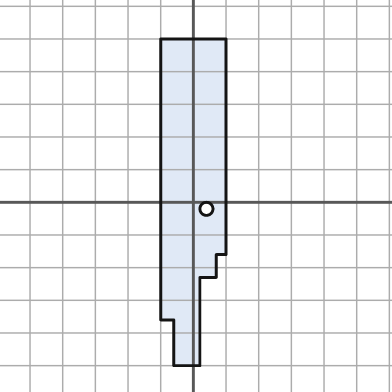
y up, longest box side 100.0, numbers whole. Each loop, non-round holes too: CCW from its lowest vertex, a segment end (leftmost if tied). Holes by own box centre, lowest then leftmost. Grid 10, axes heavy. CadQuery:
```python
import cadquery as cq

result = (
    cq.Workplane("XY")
    .moveTo(-6.0, -50.0)
    .lineTo(2.0, -50.0)
    .lineTo(2.0, -23.0)
    .lineTo(7.0, -23.0)
    .lineTo(7.0, -16.0)
    .lineTo(10.0, -16.0)
    .lineTo(10.0, 50.0)
    .lineTo(-10.0, 50.0)
    .lineTo(-10.0, -36.0)
    .lineTo(-6.0, -36.0)
    .close()
    .moveTo(4.0, -2.0)
    .circle(2.0)
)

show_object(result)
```